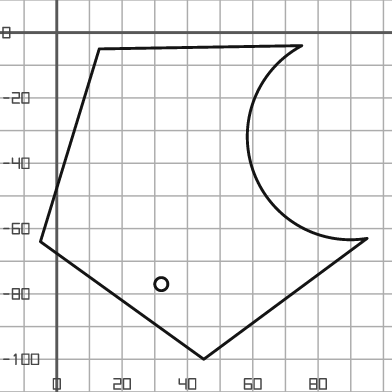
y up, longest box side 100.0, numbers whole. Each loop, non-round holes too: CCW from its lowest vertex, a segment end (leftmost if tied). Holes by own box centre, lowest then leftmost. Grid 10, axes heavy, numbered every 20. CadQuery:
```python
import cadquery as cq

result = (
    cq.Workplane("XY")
    .moveTo(45.0, -100.0)
    .lineTo(95.0, -63.0)
    .threePointArc((60.0, -42.0), (75.0, -4.0))
    .lineTo(13.0, -5.0)
    .lineTo(-5.0, -64.0)
    .close()
    .moveTo(32.0, -77.0)
    .circle(2.0)
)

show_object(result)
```